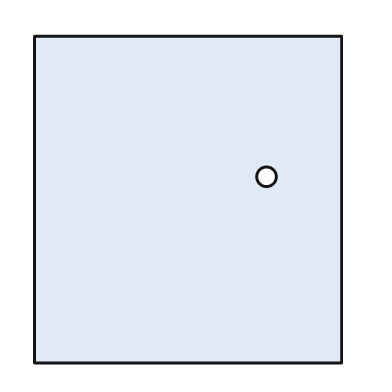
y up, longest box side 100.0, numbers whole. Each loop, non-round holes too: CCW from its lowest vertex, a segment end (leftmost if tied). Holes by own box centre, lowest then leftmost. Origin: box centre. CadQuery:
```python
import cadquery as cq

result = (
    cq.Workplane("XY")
    .moveTo(-47.0, -50.0)
    .lineTo(47.0, -50.0)
    .lineTo(47.0, 50.0)
    .lineTo(-47.0, 50.0)
    .close()
    .moveTo(24.0, 7.0)
    .circle(3.0)
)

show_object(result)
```